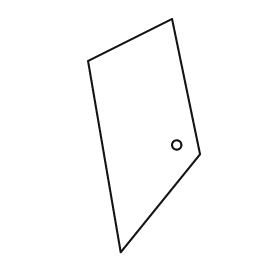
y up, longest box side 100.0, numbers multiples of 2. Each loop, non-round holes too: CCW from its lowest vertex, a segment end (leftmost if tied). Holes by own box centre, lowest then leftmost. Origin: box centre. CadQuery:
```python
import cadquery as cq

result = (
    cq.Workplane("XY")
    .moveTo(-10.0, -50.0)
    .lineTo(24.0, -8.0)
    .lineTo(12.0, 50.0)
    .lineTo(-24.0, 32.0)
    .close()
    .moveTo(14.0, -4.0)
    .circle(2.0)
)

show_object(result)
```